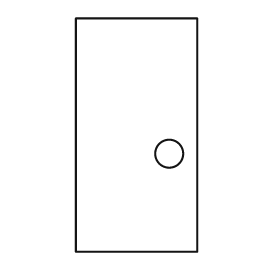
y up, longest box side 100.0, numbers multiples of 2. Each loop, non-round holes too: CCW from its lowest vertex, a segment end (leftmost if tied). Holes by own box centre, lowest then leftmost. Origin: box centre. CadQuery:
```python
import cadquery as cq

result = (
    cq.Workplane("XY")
    .moveTo(-26.0, -50.0)
    .lineTo(26.0, -50.0)
    .lineTo(26.0, 50.0)
    .lineTo(-26.0, 50.0)
    .close()
    .moveTo(14.0, -8.0)
    .circle(6.0)
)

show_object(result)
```